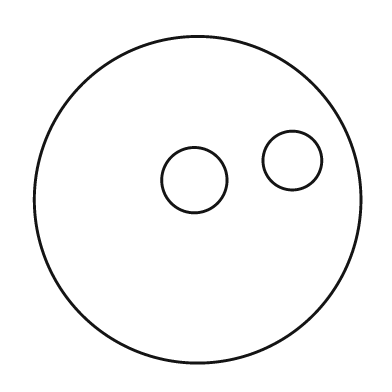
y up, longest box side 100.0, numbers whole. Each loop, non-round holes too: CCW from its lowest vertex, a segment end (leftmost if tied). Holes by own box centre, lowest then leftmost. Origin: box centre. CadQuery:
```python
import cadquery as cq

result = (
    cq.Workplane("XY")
    .moveTo(0.0, 0.0)
    .circle(50.0)
    .moveTo(-1.0, 6.0)
    .circle(10.0)
    .moveTo(29.0, 12.0)
    .circle(9.0)
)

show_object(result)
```